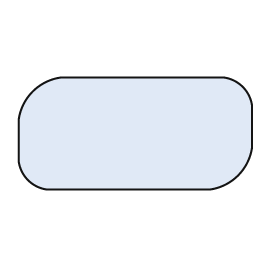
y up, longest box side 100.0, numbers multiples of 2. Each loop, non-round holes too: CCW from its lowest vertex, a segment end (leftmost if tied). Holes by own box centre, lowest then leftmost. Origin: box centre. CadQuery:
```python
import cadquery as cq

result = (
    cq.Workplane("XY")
    .moveTo(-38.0, -24.0)
    .lineTo(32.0, -24.0)
    .threePointArc((44.0, -18.0), (50.0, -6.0))
    .lineTo(50.0, 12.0)
    .threePointArc((46.0, 20.0), (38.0, 24.0))
    .lineTo(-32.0, 24.0)
    .threePointArc((-44.0, 18.0), (-50.0, 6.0))
    .lineTo(-50.0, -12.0)
    .threePointArc((-46.0, -20.0), (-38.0, -24.0))
    .close()
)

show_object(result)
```